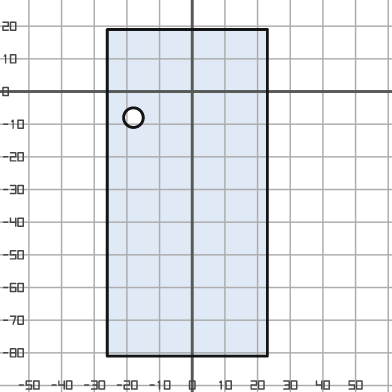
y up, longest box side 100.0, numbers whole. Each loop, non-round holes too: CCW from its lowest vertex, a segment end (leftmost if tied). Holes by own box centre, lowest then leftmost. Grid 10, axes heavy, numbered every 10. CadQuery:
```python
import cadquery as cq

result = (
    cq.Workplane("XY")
    .moveTo(-26.0, -81.0)
    .lineTo(23.0, -81.0)
    .lineTo(23.0, 19.0)
    .lineTo(-26.0, 19.0)
    .close()
    .moveTo(-18.0, -8.0)
    .circle(3.0)
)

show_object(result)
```